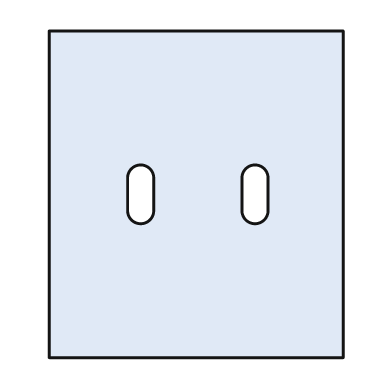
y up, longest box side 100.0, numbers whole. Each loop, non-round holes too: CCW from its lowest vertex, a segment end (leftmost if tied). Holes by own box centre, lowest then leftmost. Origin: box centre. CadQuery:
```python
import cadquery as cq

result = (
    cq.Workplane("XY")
    .moveTo(-45.0, -50.0)
    .lineTo(45.0, -50.0)
    .lineTo(45.0, 50.0)
    .lineTo(-45.0, 50.0)
    .close()
    .moveTo(-21.0, -5.0)
    .threePointArc((-17.0, -9.0), (-13.0, -5.0))
    .lineTo(-13.0, 5.0)
    .threePointArc((-17.0, 9.0), (-21.0, 5.0))
    .close()
    .moveTo(14.0, -5.0)
    .threePointArc((18.0, -9.0), (22.0, -5.0))
    .lineTo(22.0, 5.0)
    .threePointArc((18.0, 9.0), (14.0, 5.0))
    .close()
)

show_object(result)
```